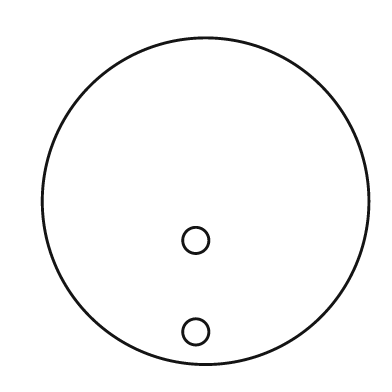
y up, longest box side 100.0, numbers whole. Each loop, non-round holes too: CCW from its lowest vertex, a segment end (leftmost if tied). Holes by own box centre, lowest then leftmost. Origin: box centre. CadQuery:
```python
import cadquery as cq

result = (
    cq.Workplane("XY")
    .moveTo(0.0, 0.0)
    .circle(50.0)
    .moveTo(-3.0, -40.0)
    .circle(4.0)
    .moveTo(-3.0, -12.0)
    .circle(4.0)
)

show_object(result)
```